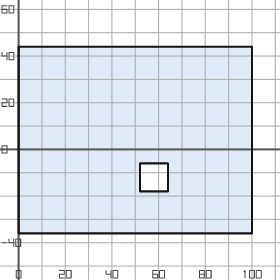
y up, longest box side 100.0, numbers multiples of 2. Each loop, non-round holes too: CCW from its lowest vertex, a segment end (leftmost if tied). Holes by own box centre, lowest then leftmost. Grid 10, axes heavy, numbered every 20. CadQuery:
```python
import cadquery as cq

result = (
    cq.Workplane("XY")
    .moveTo(0.0, -36.0)
    .lineTo(100.0, -36.0)
    .lineTo(100.0, 44.0)
    .lineTo(0.0, 44.0)
    .close()
    .moveTo(52.0, -18.0)
    .lineTo(64.0, -18.0)
    .lineTo(64.0, -6.0)
    .lineTo(52.0, -6.0)
    .close()
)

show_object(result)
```